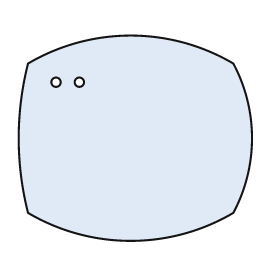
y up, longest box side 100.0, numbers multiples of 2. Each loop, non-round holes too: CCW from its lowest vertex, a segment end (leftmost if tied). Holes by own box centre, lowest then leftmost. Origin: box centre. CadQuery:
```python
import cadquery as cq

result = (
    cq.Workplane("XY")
    .moveTo(-46.0, -32.0)
    .threePointArc((-2.0, -44.0), (42.0, -32.0))
    .threePointArc((50.0, 0.0), (42.0, 32.0))
    .threePointArc((-2.0, 44.0), (-46.0, 32.0))
    .threePointArc((-50.0, 0.0), (-46.0, -32.0))
    .close()
    .moveTo(-34.0, 24.0)
    .circle(2.0)
    .moveTo(-24.0, 24.0)
    .circle(2.0)
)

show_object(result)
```